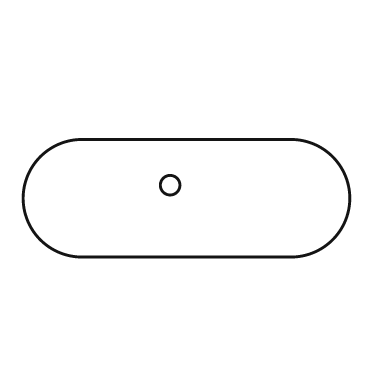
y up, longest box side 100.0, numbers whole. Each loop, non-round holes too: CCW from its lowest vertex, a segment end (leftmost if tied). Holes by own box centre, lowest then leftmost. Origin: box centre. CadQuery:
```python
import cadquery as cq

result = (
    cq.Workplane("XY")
    .moveTo(-32.0, -18.0)
    .lineTo(32.0, -18.0)
    .threePointArc((50.0, 0.0), (32.0, 18.0))
    .lineTo(-32.0, 18.0)
    .threePointArc((-50.0, 0.0), (-32.0, -18.0))
    .close()
    .moveTo(-5.0, 4.0)
    .circle(3.0)
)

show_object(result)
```